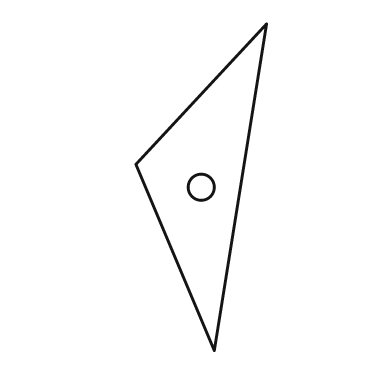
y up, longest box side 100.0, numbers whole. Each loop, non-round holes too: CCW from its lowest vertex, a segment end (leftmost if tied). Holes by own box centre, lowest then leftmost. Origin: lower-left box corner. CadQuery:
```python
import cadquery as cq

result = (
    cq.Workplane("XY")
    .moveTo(24.0, 0.0)
    .lineTo(40.0, 100.0)
    .lineTo(0.0, 57.0)
    .close()
    .moveTo(20.0, 50.0)
    .circle(4.0)
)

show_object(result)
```